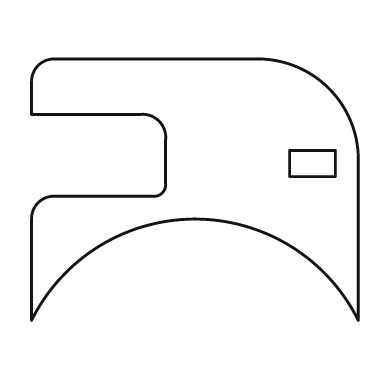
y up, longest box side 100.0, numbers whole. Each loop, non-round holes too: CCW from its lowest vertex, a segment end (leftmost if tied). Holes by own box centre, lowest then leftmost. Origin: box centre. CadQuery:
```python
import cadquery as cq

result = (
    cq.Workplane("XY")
    .moveTo(-50.0, -40.0)
    .threePointArc((0.0, -9.0), (50.0, -40.0))
    .lineTo(50.0, 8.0)
    .threePointArc((41.0, 31.0), (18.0, 40.0))
    .lineTo(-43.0, 40.0)
    .threePointArc((-48.0, 38.0), (-50.0, 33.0))
    .lineTo(-50.0, 23.0)
    .lineTo(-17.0, 23.0)
    .threePointArc((-11.0, 21.0), (-9.0, 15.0))
    .lineTo(-9.0, 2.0)
    .threePointArc((-10.0, -1.0), (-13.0, -2.0))
    .lineTo(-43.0, -2.0)
    .threePointArc((-48.0, -4.0), (-50.0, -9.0))
    .close()
    .moveTo(29.0, 4.0)
    .lineTo(43.0, 4.0)
    .lineTo(43.0, 12.0)
    .lineTo(29.0, 12.0)
    .close()
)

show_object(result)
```